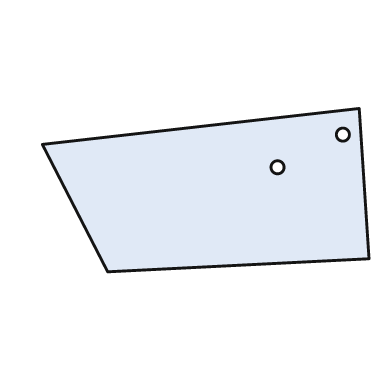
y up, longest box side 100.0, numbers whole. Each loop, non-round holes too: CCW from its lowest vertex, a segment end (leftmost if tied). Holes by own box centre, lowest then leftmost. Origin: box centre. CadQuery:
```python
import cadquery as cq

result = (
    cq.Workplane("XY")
    .moveTo(-30.0, -25.0)
    .lineTo(50.0, -21.0)
    .lineTo(47.0, 25.0)
    .lineTo(-50.0, 14.0)
    .close()
    .moveTo(22.0, 7.0)
    .circle(2.0)
    .moveTo(42.0, 17.0)
    .circle(2.0)
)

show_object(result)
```